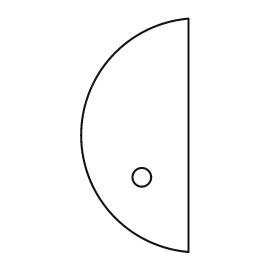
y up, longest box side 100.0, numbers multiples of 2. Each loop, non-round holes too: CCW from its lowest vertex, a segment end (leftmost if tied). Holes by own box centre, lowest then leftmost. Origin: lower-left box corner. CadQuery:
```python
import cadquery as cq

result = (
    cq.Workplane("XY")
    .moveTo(46.0, 0.0)
    .lineTo(46.0, 100.0)
    .threePointArc((0.0, 50.0), (46.0, 0.0))
    .close()
    .moveTo(26.0, 32.0)
    .circle(4.0)
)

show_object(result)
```